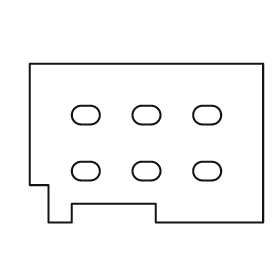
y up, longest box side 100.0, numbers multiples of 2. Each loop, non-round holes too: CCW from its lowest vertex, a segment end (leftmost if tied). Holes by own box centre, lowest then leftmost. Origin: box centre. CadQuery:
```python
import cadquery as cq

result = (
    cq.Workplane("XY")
    .moveTo(-42.0, -34.0)
    .lineTo(-32.0, -34.0)
    .lineTo(-32.0, -26.0)
    .lineTo(4.0, -26.0)
    .lineTo(4.0, -34.0)
    .lineTo(50.0, -34.0)
    .lineTo(50.0, 34.0)
    .lineTo(-50.0, 34.0)
    .lineTo(-50.0, -18.0)
    .lineTo(-42.0, -18.0)
    .close()
    .moveTo(-28.0, -16.0)
    .lineTo(-24.0, -16.0)
    .threePointArc((-20.0, -12.0), (-24.0, -8.0))
    .lineTo(-28.0, -8.0)
    .threePointArc((-32.0, -12.0), (-28.0, -16.0))
    .close()
    .moveTo(-2.0, -16.0)
    .lineTo(2.0, -16.0)
    .threePointArc((6.0, -12.0), (2.0, -8.0))
    .lineTo(-2.0, -8.0)
    .threePointArc((-6.0, -12.0), (-2.0, -16.0))
    .close()
    .moveTo(24.0, -16.0)
    .lineTo(28.0, -16.0)
    .threePointArc((32.0, -12.0), (28.0, -8.0))
    .lineTo(24.0, -8.0)
    .threePointArc((20.0, -12.0), (24.0, -16.0))
    .close()
    .moveTo(-28.0, 8.0)
    .lineTo(-24.0, 8.0)
    .threePointArc((-20.0, 12.0), (-24.0, 16.0))
    .lineTo(-28.0, 16.0)
    .threePointArc((-32.0, 12.0), (-28.0, 8.0))
    .close()
    .moveTo(-2.0, 8.0)
    .lineTo(2.0, 8.0)
    .threePointArc((6.0, 12.0), (2.0, 16.0))
    .lineTo(-2.0, 16.0)
    .threePointArc((-6.0, 12.0), (-2.0, 8.0))
    .close()
    .moveTo(24.0, 8.0)
    .lineTo(28.0, 8.0)
    .threePointArc((32.0, 12.0), (28.0, 16.0))
    .lineTo(24.0, 16.0)
    .threePointArc((20.0, 12.0), (24.0, 8.0))
    .close()
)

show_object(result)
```